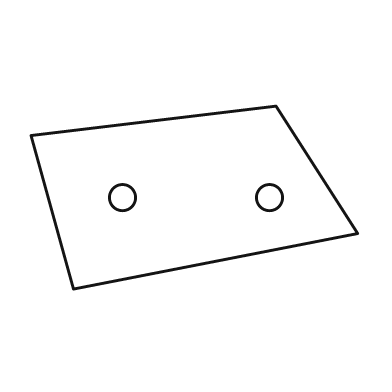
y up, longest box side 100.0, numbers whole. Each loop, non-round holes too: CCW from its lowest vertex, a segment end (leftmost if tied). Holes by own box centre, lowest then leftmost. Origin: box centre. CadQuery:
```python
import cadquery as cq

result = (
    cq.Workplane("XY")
    .moveTo(-37.0, -28.0)
    .lineTo(50.0, -11.0)
    .lineTo(25.0, 28.0)
    .lineTo(-50.0, 19.0)
    .close()
    .moveTo(-22.0, 0.0)
    .circle(4.0)
    .moveTo(23.0, 0.0)
    .circle(4.0)
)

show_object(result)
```